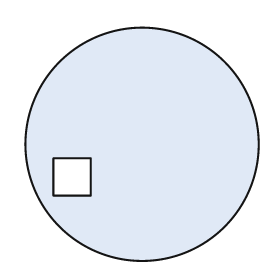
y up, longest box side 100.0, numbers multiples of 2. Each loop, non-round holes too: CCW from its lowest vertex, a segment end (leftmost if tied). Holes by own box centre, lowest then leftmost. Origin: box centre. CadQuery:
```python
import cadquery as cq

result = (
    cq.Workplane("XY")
    .moveTo(0.0, 0.0)
    .circle(50.0)
    .moveTo(-38.0, -22.0)
    .lineTo(-22.0, -22.0)
    .lineTo(-22.0, -6.0)
    .lineTo(-38.0, -6.0)
    .close()
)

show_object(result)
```